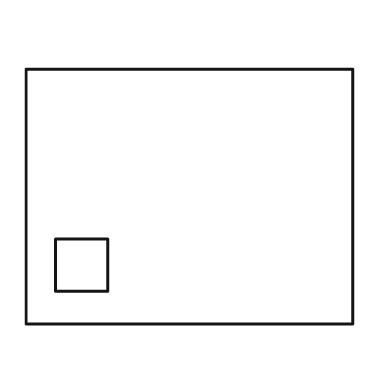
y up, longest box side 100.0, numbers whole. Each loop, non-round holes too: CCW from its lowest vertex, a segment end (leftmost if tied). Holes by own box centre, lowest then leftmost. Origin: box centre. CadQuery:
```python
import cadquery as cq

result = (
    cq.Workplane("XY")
    .moveTo(-50.0, -39.0)
    .lineTo(50.0, -39.0)
    .lineTo(50.0, 39.0)
    .lineTo(-50.0, 39.0)
    .close()
    .moveTo(-41.0, -29.0)
    .lineTo(-25.0, -29.0)
    .lineTo(-25.0, -13.0)
    .lineTo(-41.0, -13.0)
    .close()
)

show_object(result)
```